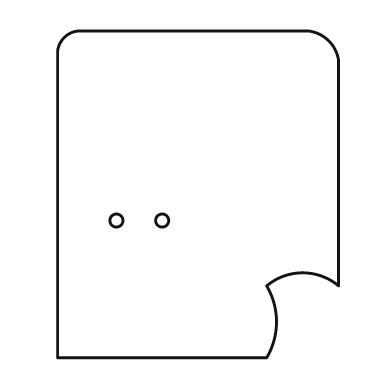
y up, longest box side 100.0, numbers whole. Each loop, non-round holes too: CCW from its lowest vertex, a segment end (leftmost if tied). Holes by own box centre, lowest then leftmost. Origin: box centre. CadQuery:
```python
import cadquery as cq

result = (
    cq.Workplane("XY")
    .moveTo(-43.0, -50.0)
    .lineTo(21.0, -50.0)
    .threePointArc((24.0, -39.0), (21.0, -28.0))
    .threePointArc((32.0, -24.0), (43.0, -28.0))
    .lineTo(43.0, 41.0)
    .threePointArc((40.0, 47.0), (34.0, 50.0))
    .lineTo(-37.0, 50.0)
    .threePointArc((-41.0, 48.0), (-43.0, 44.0))
    .close()
    .moveTo(-25.0, -8.0)
    .circle(2.0)
    .moveTo(-11.0, -8.0)
    .circle(2.0)
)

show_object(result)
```